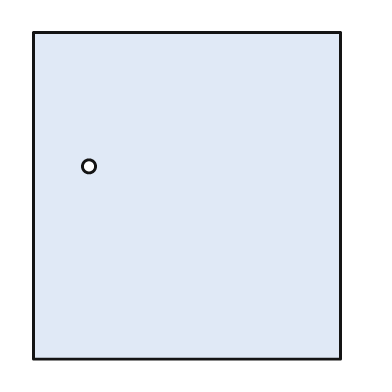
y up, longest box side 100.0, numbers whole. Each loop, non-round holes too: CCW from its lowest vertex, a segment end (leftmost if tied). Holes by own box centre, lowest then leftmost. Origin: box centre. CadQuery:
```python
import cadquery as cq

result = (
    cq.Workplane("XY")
    .moveTo(-47.0, -50.0)
    .lineTo(47.0, -50.0)
    .lineTo(47.0, 50.0)
    .lineTo(-47.0, 50.0)
    .close()
    .moveTo(-30.0, 9.0)
    .circle(2.0)
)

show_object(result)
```